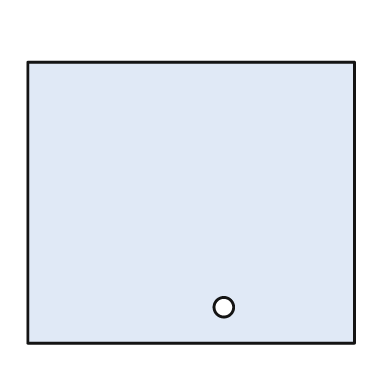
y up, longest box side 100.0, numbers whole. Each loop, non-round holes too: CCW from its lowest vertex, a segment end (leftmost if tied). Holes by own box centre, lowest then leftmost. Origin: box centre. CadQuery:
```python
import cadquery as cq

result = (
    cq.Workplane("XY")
    .moveTo(-50.0, -43.0)
    .lineTo(50.0, -43.0)
    .lineTo(50.0, 43.0)
    .lineTo(-50.0, 43.0)
    .close()
    .moveTo(10.0, -32.0)
    .circle(3.0)
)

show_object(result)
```